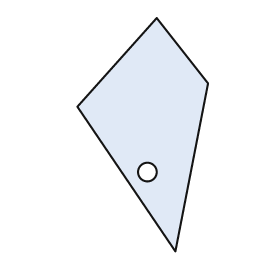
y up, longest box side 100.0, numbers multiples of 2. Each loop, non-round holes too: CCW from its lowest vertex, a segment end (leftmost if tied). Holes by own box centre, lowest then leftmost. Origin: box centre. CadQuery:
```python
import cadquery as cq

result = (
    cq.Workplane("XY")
    .moveTo(14.0, -50.0)
    .lineTo(28.0, 22.0)
    .lineTo(6.0, 50.0)
    .lineTo(-28.0, 12.0)
    .close()
    .moveTo(2.0, -16.0)
    .circle(4.0)
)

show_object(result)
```